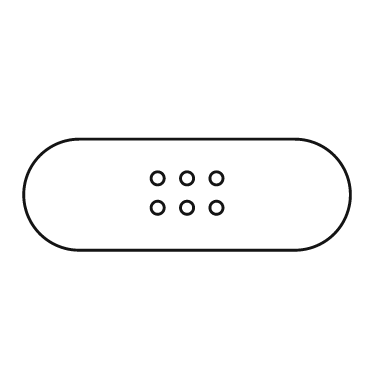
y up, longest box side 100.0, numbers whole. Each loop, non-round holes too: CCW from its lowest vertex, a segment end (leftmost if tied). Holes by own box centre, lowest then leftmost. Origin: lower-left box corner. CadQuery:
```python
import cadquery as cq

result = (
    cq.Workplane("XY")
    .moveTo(17.0, 0.0)
    .lineTo(83.0, 0.0)
    .threePointArc((100.0, 17.0), (83.0, 34.0))
    .lineTo(17.0, 34.0)
    .threePointArc((0.0, 17.0), (17.0, 0.0))
    .close()
    .moveTo(41.0, 13.0)
    .circle(2.0)
    .moveTo(50.0, 13.0)
    .circle(2.0)
    .moveTo(59.0, 13.0)
    .circle(2.0)
    .moveTo(41.0, 22.0)
    .circle(2.0)
    .moveTo(50.0, 22.0)
    .circle(2.0)
    .moveTo(59.0, 22.0)
    .circle(2.0)
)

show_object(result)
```